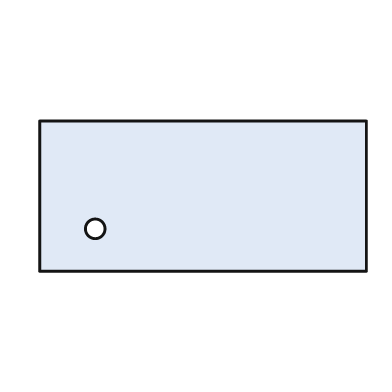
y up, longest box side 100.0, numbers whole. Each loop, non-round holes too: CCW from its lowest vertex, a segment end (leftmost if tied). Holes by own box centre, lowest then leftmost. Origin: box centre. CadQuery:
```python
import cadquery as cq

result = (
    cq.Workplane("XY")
    .moveTo(-50.0, -23.0)
    .lineTo(50.0, -23.0)
    .lineTo(50.0, 23.0)
    .lineTo(-50.0, 23.0)
    .close()
    .moveTo(-33.0, -10.0)
    .circle(3.0)
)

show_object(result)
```